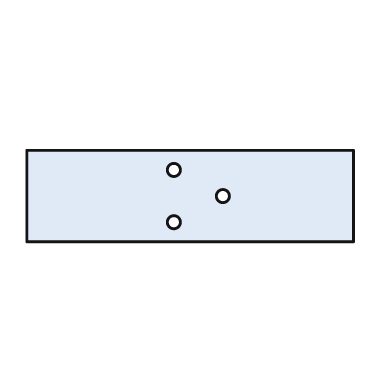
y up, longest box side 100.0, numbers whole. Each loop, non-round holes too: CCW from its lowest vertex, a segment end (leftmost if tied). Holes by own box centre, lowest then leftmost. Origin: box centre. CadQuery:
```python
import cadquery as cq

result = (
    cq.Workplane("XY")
    .moveTo(-50.0, -14.0)
    .lineTo(50.0, -14.0)
    .lineTo(50.0, 14.0)
    .lineTo(-50.0, 14.0)
    .close()
    .moveTo(-5.0, -8.0)
    .circle(2.0)
    .moveTo(10.0, 0.0)
    .circle(2.0)
    .moveTo(-5.0, 8.0)
    .circle(2.0)
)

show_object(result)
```